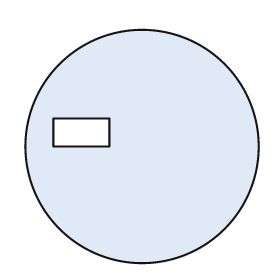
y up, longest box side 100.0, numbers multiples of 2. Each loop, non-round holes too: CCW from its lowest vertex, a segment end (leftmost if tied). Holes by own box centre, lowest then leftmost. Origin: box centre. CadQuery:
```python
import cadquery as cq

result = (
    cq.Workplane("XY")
    .moveTo(0.0, 0.0)
    .circle(50.0)
    .moveTo(-38.0, 0.0)
    .lineTo(-14.0, 0.0)
    .lineTo(-14.0, 12.0)
    .lineTo(-38.0, 12.0)
    .close()
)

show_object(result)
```